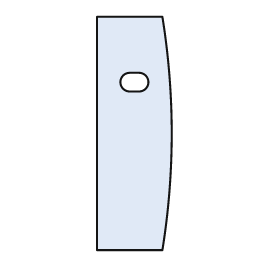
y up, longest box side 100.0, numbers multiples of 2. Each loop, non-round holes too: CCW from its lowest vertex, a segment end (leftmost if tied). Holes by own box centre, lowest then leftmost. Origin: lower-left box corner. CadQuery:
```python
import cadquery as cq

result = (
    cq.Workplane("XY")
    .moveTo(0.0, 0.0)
    .lineTo(28.0, 0.0)
    .threePointArc((32.0, 50.0), (28.0, 100.0))
    .lineTo(0.0, 100.0)
    .close()
    .moveTo(14.0, 68.0)
    .lineTo(18.0, 68.0)
    .threePointArc((22.0, 72.0), (18.0, 76.0))
    .lineTo(14.0, 76.0)
    .threePointArc((10.0, 72.0), (14.0, 68.0))
    .close()
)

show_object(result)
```